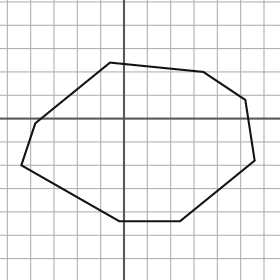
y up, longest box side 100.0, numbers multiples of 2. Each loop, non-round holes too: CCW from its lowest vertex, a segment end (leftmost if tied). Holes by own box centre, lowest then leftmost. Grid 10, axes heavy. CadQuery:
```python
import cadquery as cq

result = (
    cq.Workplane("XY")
    .moveTo(-2.0, -44.0)
    .lineTo(24.0, -44.0)
    .lineTo(56.0, -18.0)
    .lineTo(52.0, 8.0)
    .lineTo(34.0, 20.0)
    .lineTo(-6.0, 24.0)
    .lineTo(-38.0, -2.0)
    .lineTo(-44.0, -20.0)
    .close()
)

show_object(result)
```